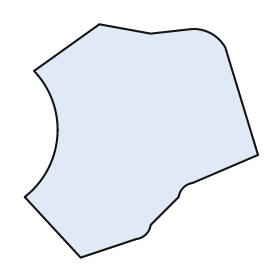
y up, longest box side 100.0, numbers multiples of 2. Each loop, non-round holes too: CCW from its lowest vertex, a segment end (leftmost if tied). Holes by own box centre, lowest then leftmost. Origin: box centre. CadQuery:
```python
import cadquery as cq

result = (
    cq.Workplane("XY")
    .moveTo(-26.0, -50.0)
    .lineTo(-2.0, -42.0)
    .threePointArc((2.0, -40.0), (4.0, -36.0))
    .lineTo(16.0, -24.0)
    .threePointArc((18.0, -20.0), (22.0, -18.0))
    .lineTo(50.0, -6.0)
    .lineTo(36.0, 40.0)
    .threePointArc((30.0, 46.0), (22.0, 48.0))
    .lineTo(4.0, 46.0)
    .lineTo(-18.0, 50.0)
    .lineTo(-46.0, 30.0)
    .threePointArc((-36.0, 2.0), (-50.0, -24.0))
    .close()
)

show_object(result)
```